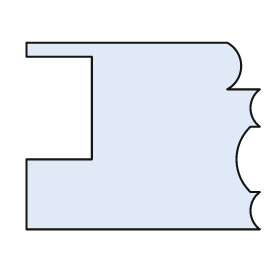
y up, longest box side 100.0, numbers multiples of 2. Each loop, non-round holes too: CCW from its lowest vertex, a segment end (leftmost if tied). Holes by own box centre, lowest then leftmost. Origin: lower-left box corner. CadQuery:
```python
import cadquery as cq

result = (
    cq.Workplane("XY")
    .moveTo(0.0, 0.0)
    .lineTo(100.0, 0.0)
    .threePointArc((96.0, 8.0), (100.0, 16.0))
    .lineTo(96.0, 16.0)
    .threePointArc((90.0, 30.0), (96.0, 44.0))
    .lineTo(100.0, 44.0)
    .threePointArc((96.0, 52.0), (100.0, 60.0))
    .lineTo(86.0, 60.0)
    .threePointArc((92.0, 70.0), (86.0, 80.0))
    .lineTo(0.0, 80.0)
    .lineTo(0.0, 74.0)
    .lineTo(28.0, 74.0)
    .lineTo(28.0, 30.0)
    .lineTo(0.0, 30.0)
    .close()
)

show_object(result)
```